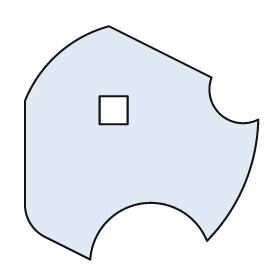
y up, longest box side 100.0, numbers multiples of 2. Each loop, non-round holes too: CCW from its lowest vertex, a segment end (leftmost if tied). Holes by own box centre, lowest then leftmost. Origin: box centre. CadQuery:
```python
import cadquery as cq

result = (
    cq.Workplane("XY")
    .moveTo(-22.0, -50.0)
    .threePointArc((0.0, -26.0), (28.0, -42.0))
    .threePointArc((44.0, -18.0), (50.0, 10.0))
    .threePointArc((34.0, 12.0), (30.0, 28.0))
    .lineTo(-14.0, 50.0)
    .threePointArc((-36.0, 38.0), (-50.0, 18.0))
    .lineTo(-50.0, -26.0)
    .threePointArc((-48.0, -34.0), (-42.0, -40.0))
    .close()
    .moveTo(-18.0, 8.0)
    .lineTo(-6.0, 8.0)
    .lineTo(-6.0, 20.0)
    .lineTo(-18.0, 20.0)
    .close()
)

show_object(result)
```